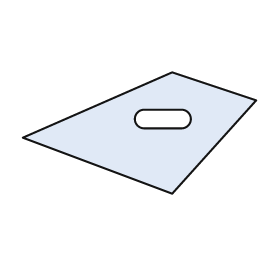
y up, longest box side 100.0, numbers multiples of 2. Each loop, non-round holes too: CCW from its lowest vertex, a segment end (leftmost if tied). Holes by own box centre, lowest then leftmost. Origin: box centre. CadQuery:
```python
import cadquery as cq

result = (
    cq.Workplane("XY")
    .moveTo(14.0, -26.0)
    .lineTo(50.0, 14.0)
    .lineTo(14.0, 26.0)
    .lineTo(-50.0, -2.0)
    .close()
    .moveTo(2.0, 2.0)
    .lineTo(18.0, 2.0)
    .threePointArc((22.0, 6.0), (18.0, 10.0))
    .lineTo(2.0, 10.0)
    .threePointArc((-2.0, 6.0), (2.0, 2.0))
    .close()
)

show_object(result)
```